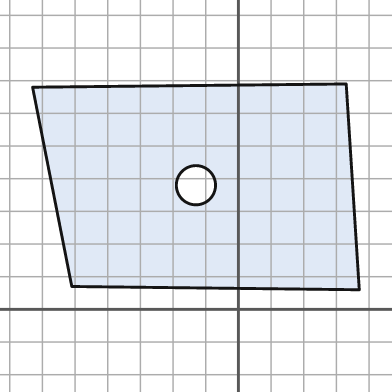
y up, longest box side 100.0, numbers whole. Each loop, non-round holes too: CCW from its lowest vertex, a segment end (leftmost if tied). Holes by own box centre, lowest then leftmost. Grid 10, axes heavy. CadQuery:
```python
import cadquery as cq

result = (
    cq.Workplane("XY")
    .moveTo(37.0, 6.0)
    .lineTo(33.0, 69.0)
    .lineTo(-63.0, 68.0)
    .lineTo(-51.0, 7.0)
    .close()
    .moveTo(-13.0, 38.0)
    .circle(6.0)
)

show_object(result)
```